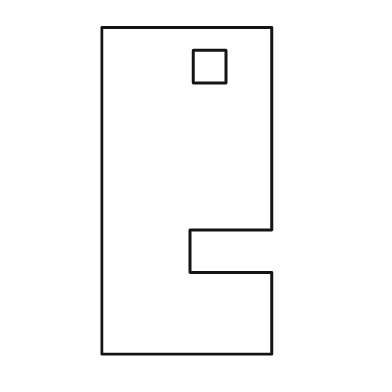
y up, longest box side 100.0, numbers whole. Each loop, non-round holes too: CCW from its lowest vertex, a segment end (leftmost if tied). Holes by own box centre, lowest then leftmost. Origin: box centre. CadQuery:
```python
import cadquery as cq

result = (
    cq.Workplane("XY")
    .moveTo(-26.0, -50.0)
    .lineTo(26.0, -50.0)
    .lineTo(26.0, -25.0)
    .lineTo(1.0, -25.0)
    .lineTo(1.0, -12.0)
    .lineTo(26.0, -12.0)
    .lineTo(26.0, 50.0)
    .lineTo(-26.0, 50.0)
    .close()
    .moveTo(2.0, 33.0)
    .lineTo(12.0, 33.0)
    .lineTo(12.0, 43.0)
    .lineTo(2.0, 43.0)
    .close()
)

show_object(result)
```